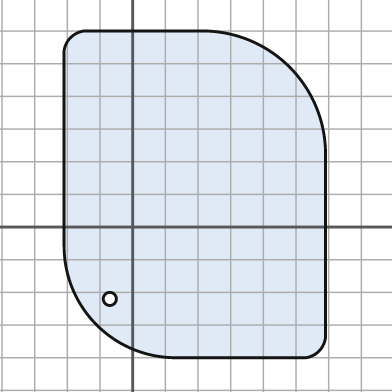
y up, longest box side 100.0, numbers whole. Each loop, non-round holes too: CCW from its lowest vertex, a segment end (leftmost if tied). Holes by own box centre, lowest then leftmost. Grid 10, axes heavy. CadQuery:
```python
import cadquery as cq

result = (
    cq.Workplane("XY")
    .moveTo(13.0, -40.0)
    .lineTo(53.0, -40.0)
    .threePointArc((57.0, -38.0), (59.0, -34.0))
    .lineTo(59.0, 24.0)
    .threePointArc((48.0, 49.0), (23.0, 60.0))
    .lineTo(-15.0, 60.0)
    .threePointArc((-19.0, 58.0), (-21.0, 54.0))
    .lineTo(-21.0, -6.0)
    .threePointArc((-11.0, -30.0), (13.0, -40.0))
    .close()
    .moveTo(-7.0, -22.0)
    .circle(2.0)
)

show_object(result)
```